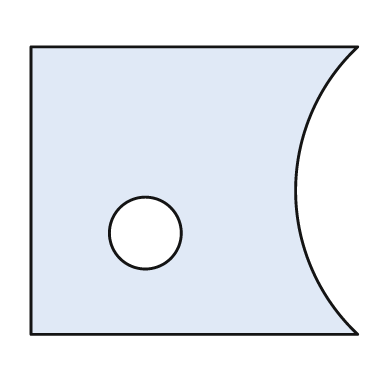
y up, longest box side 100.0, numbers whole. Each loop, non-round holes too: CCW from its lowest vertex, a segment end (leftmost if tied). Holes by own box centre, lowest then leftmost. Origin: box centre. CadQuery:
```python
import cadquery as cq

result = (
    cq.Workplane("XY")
    .moveTo(-50.0, -44.0)
    .lineTo(50.0, -44.0)
    .threePointArc((31.0, 0.0), (50.0, 44.0))
    .lineTo(-50.0, 44.0)
    .close()
    .moveTo(-15.0, -13.0)
    .circle(11.0)
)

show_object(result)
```